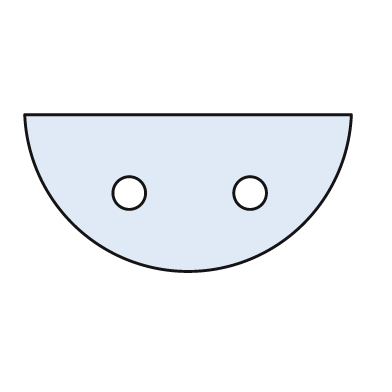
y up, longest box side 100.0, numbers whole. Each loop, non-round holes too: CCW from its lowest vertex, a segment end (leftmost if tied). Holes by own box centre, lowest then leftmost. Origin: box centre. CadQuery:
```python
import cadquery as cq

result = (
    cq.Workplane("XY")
    .moveTo(-50.0, 24.0)
    .threePointArc((0.0, -24.0), (50.0, 24.0))
    .close()
    .moveTo(-18.0, 0.0)
    .circle(5.0)
    .moveTo(19.0, 0.0)
    .circle(5.0)
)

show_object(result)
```